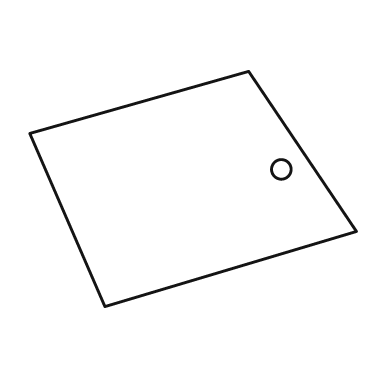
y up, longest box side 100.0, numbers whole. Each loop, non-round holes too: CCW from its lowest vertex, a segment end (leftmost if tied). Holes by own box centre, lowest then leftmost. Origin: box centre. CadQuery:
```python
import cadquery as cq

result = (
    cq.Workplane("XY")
    .moveTo(-27.0, -36.0)
    .lineTo(50.0, -13.0)
    .lineTo(17.0, 36.0)
    .lineTo(-50.0, 17.0)
    .close()
    .moveTo(27.0, 6.0)
    .circle(3.0)
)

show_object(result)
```